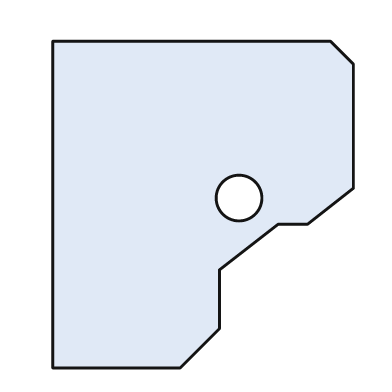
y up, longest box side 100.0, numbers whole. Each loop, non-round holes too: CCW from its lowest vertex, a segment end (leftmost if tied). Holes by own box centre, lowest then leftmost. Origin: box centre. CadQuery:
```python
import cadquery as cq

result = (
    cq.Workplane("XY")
    .moveTo(-46.0, -50.0)
    .lineTo(-7.0, -50.0)
    .lineTo(5.0, -38.0)
    .lineTo(5.0, -20.0)
    .lineTo(23.0, -6.0)
    .lineTo(32.0, -6.0)
    .lineTo(46.0, 5.0)
    .lineTo(46.0, 43.0)
    .lineTo(39.0, 50.0)
    .lineTo(-46.0, 50.0)
    .close()
    .moveTo(11.0, 2.0)
    .circle(7.0)
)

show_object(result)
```